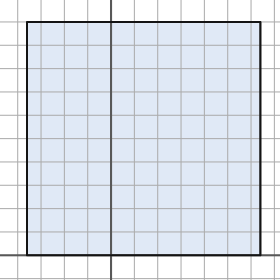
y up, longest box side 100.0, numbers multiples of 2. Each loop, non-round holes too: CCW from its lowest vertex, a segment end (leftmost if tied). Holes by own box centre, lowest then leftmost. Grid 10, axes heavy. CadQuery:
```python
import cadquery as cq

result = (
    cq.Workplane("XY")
    .moveTo(-36.0, 0.0)
    .lineTo(64.0, 0.0)
    .lineTo(64.0, 100.0)
    .lineTo(-36.0, 100.0)
    .close()
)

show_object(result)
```